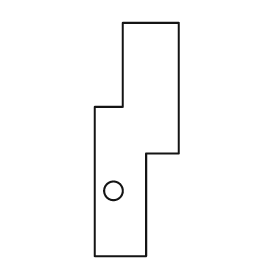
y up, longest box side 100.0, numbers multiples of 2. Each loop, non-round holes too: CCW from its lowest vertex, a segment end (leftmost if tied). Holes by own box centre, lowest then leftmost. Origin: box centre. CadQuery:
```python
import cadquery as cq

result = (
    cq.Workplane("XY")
    .moveTo(-18.0, -50.0)
    .lineTo(4.0, -50.0)
    .lineTo(4.0, -6.0)
    .lineTo(18.0, -6.0)
    .lineTo(18.0, 50.0)
    .lineTo(-6.0, 50.0)
    .lineTo(-6.0, 14.0)
    .lineTo(-18.0, 14.0)
    .close()
    .moveTo(-10.0, -22.0)
    .circle(4.0)
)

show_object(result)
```